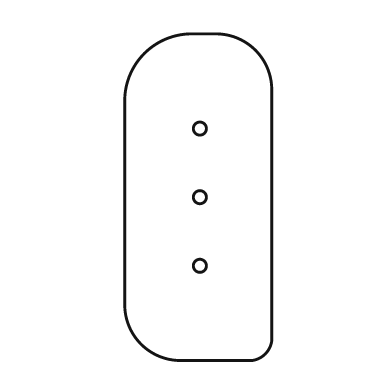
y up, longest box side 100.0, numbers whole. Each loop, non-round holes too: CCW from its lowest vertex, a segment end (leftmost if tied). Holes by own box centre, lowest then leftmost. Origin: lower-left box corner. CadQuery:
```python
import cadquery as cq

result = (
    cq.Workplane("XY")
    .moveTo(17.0, 0.0)
    .lineTo(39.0, 0.0)
    .threePointArc((43.0, 2.0), (45.0, 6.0))
    .lineTo(45.0, 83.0)
    .threePointArc((40.0, 95.0), (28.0, 100.0))
    .lineTo(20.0, 100.0)
    .threePointArc((6.0, 94.0), (0.0, 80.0))
    .lineTo(0.0, 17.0)
    .threePointArc((5.0, 5.0), (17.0, 0.0))
    .close()
    .moveTo(23.0, 29.0)
    .circle(2.0)
    .moveTo(23.0, 50.0)
    .circle(2.0)
    .moveTo(23.0, 71.0)
    .circle(2.0)
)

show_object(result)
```